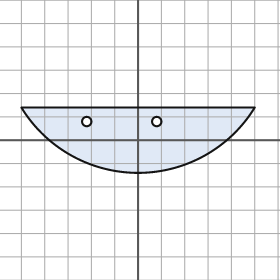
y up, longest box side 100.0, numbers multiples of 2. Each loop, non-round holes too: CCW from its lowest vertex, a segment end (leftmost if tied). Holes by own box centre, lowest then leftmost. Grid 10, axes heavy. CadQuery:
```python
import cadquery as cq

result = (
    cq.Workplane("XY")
    .moveTo(-50.0, 14.0)
    .threePointArc((0.0, -14.0), (50.0, 14.0))
    .close()
    .moveTo(-22.0, 8.0)
    .circle(2.0)
    .moveTo(8.0, 8.0)
    .circle(2.0)
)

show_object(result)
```